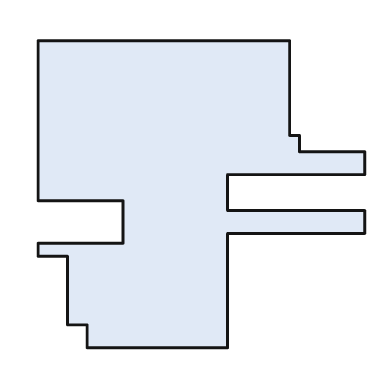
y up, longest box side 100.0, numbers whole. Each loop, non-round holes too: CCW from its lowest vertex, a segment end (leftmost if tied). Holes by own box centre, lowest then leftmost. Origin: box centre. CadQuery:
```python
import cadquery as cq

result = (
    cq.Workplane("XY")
    .moveTo(-35.0, -47.0)
    .lineTo(8.0, -47.0)
    .lineTo(8.0, -12.0)
    .lineTo(50.0, -12.0)
    .lineTo(50.0, -5.0)
    .lineTo(8.0, -5.0)
    .lineTo(8.0, 6.0)
    .lineTo(50.0, 6.0)
    .lineTo(50.0, 13.0)
    .lineTo(30.0, 13.0)
    .lineTo(30.0, 18.0)
    .lineTo(27.0, 18.0)
    .lineTo(27.0, 47.0)
    .lineTo(-50.0, 47.0)
    .lineTo(-50.0, -2.0)
    .lineTo(-24.0, -2.0)
    .lineTo(-24.0, -15.0)
    .lineTo(-50.0, -15.0)
    .lineTo(-50.0, -19.0)
    .lineTo(-41.0, -19.0)
    .lineTo(-41.0, -40.0)
    .lineTo(-35.0, -40.0)
    .close()
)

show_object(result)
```